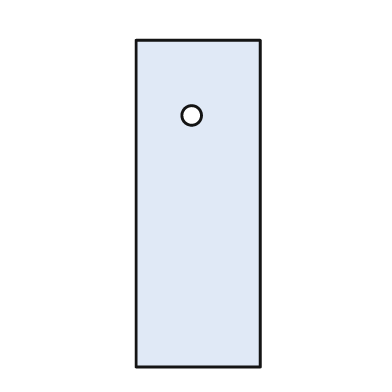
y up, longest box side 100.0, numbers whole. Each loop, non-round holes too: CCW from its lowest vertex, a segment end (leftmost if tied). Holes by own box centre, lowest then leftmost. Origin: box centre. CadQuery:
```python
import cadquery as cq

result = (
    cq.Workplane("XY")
    .moveTo(-19.0, -50.0)
    .lineTo(19.0, -50.0)
    .lineTo(19.0, 50.0)
    .lineTo(-19.0, 50.0)
    .close()
    .moveTo(-2.0, 27.0)
    .circle(3.0)
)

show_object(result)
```